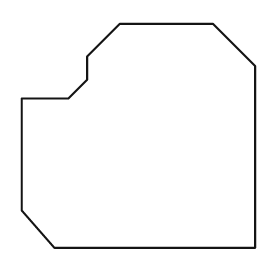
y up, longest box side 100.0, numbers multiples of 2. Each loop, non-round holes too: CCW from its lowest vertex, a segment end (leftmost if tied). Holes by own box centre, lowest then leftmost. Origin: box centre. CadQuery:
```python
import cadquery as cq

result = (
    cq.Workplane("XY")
    .moveTo(-36.0, -48.0)
    .lineTo(50.0, -48.0)
    .lineTo(50.0, 30.0)
    .lineTo(32.0, 48.0)
    .lineTo(-8.0, 48.0)
    .lineTo(-22.0, 34.0)
    .lineTo(-22.0, 24.0)
    .lineTo(-30.0, 16.0)
    .lineTo(-50.0, 16.0)
    .lineTo(-50.0, -32.0)
    .close()
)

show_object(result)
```